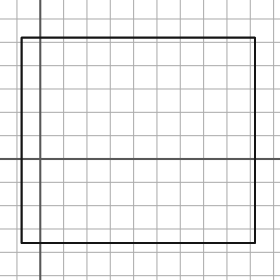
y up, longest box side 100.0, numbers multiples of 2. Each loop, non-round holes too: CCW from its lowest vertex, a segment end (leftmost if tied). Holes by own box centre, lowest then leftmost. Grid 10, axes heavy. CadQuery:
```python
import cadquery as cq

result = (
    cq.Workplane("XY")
    .moveTo(-8.0, -36.0)
    .lineTo(92.0, -36.0)
    .lineTo(92.0, 52.0)
    .lineTo(-8.0, 52.0)
    .close()
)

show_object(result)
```